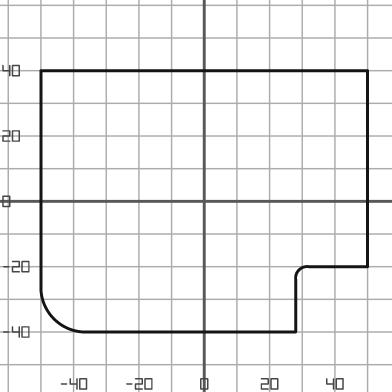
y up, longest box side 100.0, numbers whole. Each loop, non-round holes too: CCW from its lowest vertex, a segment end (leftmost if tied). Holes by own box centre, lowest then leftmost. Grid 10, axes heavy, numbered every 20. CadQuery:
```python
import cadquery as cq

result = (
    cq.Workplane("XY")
    .moveTo(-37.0, -40.0)
    .lineTo(28.0, -40.0)
    .lineTo(28.0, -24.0)
    .threePointArc((29.0, -21.0), (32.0, -20.0))
    .lineTo(50.0, -20.0)
    .lineTo(50.0, 40.0)
    .lineTo(-50.0, 40.0)
    .lineTo(-50.0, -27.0)
    .threePointArc((-46.0, -36.0), (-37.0, -40.0))
    .close()
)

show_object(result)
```